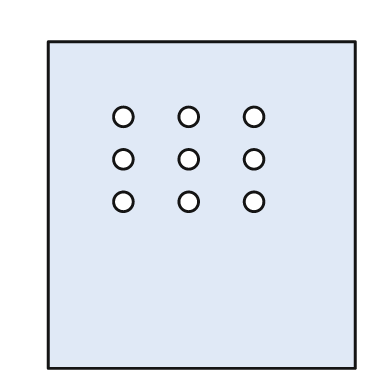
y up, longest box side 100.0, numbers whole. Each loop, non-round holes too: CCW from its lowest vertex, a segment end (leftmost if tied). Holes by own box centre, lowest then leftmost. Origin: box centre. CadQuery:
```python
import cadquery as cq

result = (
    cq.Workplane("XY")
    .moveTo(-47.0, -50.0)
    .lineTo(47.0, -50.0)
    .lineTo(47.0, 50.0)
    .lineTo(-47.0, 50.0)
    .close()
    .moveTo(-24.0, 1.0)
    .circle(3.0)
    .moveTo(-4.0, 1.0)
    .circle(3.0)
    .moveTo(16.0, 1.0)
    .circle(3.0)
    .moveTo(-24.0, 14.0)
    .circle(3.0)
    .moveTo(-4.0, 14.0)
    .circle(3.0)
    .moveTo(16.0, 14.0)
    .circle(3.0)
    .moveTo(-24.0, 27.0)
    .circle(3.0)
    .moveTo(-4.0, 27.0)
    .circle(3.0)
    .moveTo(16.0, 27.0)
    .circle(3.0)
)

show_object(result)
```